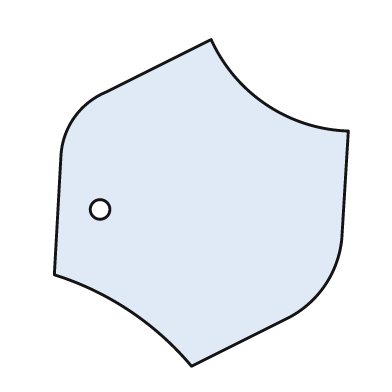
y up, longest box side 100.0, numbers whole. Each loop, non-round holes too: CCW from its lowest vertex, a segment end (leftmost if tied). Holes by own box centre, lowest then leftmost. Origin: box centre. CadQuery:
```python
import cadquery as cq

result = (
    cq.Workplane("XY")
    .moveTo(-3.0, -50.0)
    .lineTo(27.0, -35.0)
    .threePointArc((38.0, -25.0), (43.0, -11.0))
    .lineTo(45.0, 22.0)
    .threePointArc((20.0, 30.0), (3.0, 50.0))
    .lineTo(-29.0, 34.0)
    .threePointArc((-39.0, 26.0), (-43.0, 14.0))
    .lineTo(-45.0, -22.0)
    .threePointArc((-22.0, -33.0), (-3.0, -50.0))
    .close()
    .moveTo(-31.0, -2.0)
    .circle(3.0)
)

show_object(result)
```